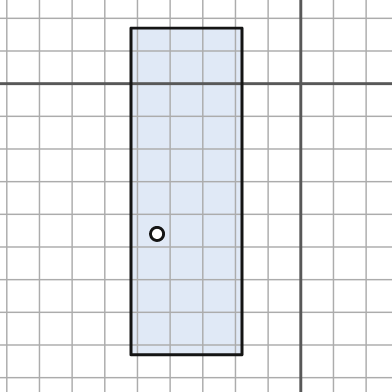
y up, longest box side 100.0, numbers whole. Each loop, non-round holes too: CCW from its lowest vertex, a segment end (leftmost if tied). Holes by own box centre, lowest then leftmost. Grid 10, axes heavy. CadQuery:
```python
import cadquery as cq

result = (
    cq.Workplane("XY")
    .moveTo(-52.0, -83.0)
    .lineTo(-18.0, -83.0)
    .lineTo(-18.0, 17.0)
    .lineTo(-52.0, 17.0)
    .close()
    .moveTo(-44.0, -46.0)
    .circle(2.0)
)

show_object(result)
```